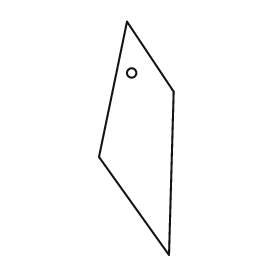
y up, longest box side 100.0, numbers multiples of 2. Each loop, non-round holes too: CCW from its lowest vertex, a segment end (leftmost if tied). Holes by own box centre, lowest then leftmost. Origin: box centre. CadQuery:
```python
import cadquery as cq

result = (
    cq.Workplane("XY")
    .moveTo(14.0, -50.0)
    .lineTo(16.0, 20.0)
    .lineTo(-4.0, 50.0)
    .lineTo(-16.0, -8.0)
    .close()
    .moveTo(-2.0, 28.0)
    .circle(2.0)
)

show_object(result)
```